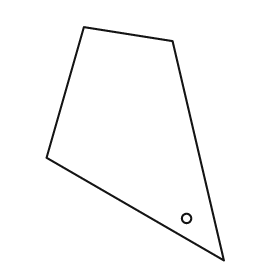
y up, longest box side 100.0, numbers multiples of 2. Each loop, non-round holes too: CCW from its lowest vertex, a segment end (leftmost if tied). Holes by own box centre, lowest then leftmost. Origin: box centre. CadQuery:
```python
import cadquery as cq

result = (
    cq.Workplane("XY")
    .moveTo(38.0, -50.0)
    .lineTo(16.0, 44.0)
    .lineTo(-22.0, 50.0)
    .lineTo(-38.0, -6.0)
    .close()
    .moveTo(22.0, -32.0)
    .circle(2.0)
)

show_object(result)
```